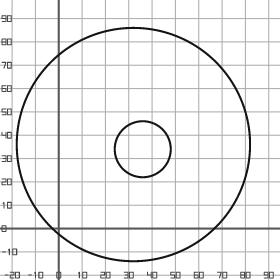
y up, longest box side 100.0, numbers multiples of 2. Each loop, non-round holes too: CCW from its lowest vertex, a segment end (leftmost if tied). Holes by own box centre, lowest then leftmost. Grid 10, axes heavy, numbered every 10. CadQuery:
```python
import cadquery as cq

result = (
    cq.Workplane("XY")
    .moveTo(32.0, 36.0)
    .circle(50.0)
    .moveTo(36.0, 34.0)
    .circle(12.0)
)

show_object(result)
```